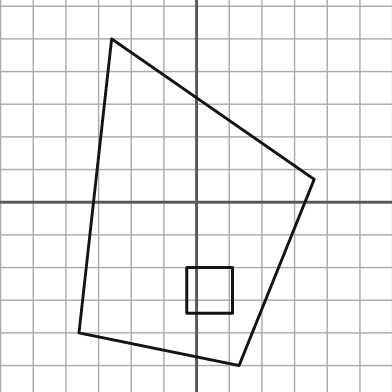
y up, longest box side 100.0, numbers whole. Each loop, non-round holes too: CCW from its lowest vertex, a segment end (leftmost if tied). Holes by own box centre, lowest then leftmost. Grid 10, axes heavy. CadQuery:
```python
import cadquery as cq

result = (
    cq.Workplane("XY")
    .moveTo(13.0, -50.0)
    .lineTo(36.0, 7.0)
    .lineTo(-26.0, 50.0)
    .lineTo(-36.0, -40.0)
    .close()
    .moveTo(-3.0, -34.0)
    .lineTo(11.0, -34.0)
    .lineTo(11.0, -20.0)
    .lineTo(-3.0, -20.0)
    .close()
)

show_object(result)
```